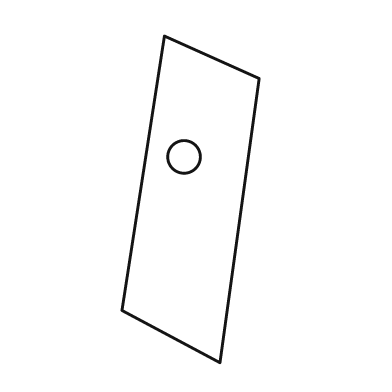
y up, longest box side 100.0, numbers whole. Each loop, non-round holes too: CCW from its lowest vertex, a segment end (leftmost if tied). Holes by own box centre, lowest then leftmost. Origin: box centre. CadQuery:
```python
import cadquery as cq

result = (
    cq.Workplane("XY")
    .moveTo(9.0, -50.0)
    .lineTo(21.0, 37.0)
    .lineTo(-8.0, 50.0)
    .lineTo(-21.0, -34.0)
    .close()
    .moveTo(-2.0, 13.0)
    .circle(5.0)
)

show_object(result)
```